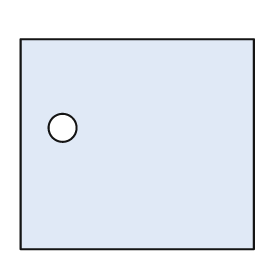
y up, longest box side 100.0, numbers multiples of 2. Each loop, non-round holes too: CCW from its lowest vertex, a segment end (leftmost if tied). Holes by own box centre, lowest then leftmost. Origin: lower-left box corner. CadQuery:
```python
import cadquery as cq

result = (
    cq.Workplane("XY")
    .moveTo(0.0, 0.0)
    .lineTo(100.0, 0.0)
    .lineTo(100.0, 90.0)
    .lineTo(0.0, 90.0)
    .close()
    .moveTo(18.0, 52.0)
    .circle(6.0)
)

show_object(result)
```